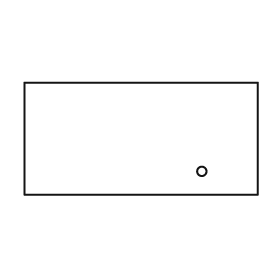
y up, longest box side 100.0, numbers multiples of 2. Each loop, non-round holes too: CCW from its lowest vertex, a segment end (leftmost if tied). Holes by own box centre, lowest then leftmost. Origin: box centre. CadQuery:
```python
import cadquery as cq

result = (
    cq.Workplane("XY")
    .moveTo(-50.0, -24.0)
    .lineTo(50.0, -24.0)
    .lineTo(50.0, 24.0)
    .lineTo(-50.0, 24.0)
    .close()
    .moveTo(26.0, -14.0)
    .circle(2.0)
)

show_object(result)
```